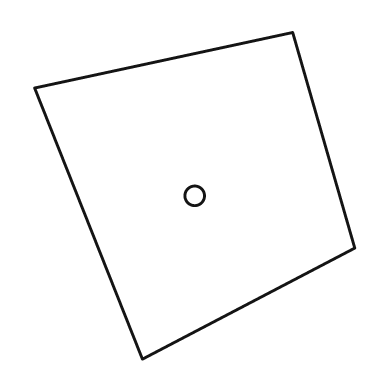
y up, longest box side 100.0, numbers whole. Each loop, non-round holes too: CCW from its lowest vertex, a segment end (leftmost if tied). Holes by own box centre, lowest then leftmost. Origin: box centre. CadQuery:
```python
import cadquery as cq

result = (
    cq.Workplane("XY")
    .moveTo(-16.0, -50.0)
    .lineTo(49.0, -16.0)
    .lineTo(30.0, 50.0)
    .lineTo(-49.0, 33.0)
    .close()
    .moveTo(0.0, 0.0)
    .circle(3.0)
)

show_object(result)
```